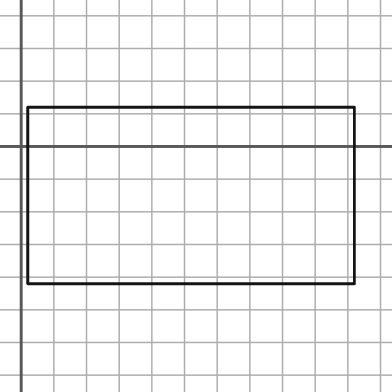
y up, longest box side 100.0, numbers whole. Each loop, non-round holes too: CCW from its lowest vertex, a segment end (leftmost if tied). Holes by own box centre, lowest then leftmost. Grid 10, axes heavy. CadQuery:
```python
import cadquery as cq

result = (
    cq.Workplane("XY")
    .moveTo(2.0, -42.0)
    .lineTo(102.0, -42.0)
    .lineTo(102.0, 12.0)
    .lineTo(2.0, 12.0)
    .close()
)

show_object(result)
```